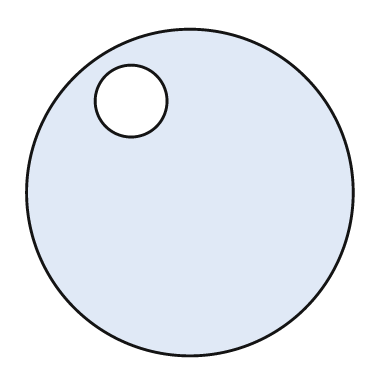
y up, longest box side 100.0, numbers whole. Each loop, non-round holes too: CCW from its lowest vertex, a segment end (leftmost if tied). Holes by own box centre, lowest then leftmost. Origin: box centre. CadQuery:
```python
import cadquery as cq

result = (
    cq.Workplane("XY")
    .moveTo(0.0, 0.0)
    .circle(50.0)
    .moveTo(-18.0, 28.0)
    .circle(11.0)
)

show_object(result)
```